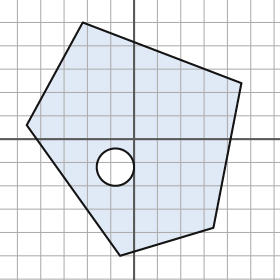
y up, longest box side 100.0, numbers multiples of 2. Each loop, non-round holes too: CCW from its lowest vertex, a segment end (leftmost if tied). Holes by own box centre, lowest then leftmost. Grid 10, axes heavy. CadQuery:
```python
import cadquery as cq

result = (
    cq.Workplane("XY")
    .moveTo(-6.0, -50.0)
    .lineTo(34.0, -38.0)
    .lineTo(46.0, 24.0)
    .lineTo(-22.0, 50.0)
    .lineTo(-46.0, 6.0)
    .close()
    .moveTo(-8.0, -12.0)
    .circle(8.0)
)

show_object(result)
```